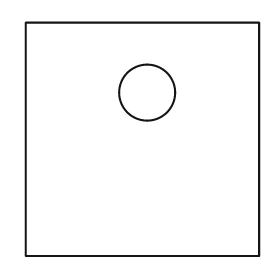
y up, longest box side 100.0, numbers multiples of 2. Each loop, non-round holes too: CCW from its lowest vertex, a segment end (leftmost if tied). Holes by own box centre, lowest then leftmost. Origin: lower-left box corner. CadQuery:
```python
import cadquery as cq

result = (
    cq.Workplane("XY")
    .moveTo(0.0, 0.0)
    .lineTo(100.0, 0.0)
    .lineTo(100.0, 100.0)
    .lineTo(0.0, 100.0)
    .close()
    .moveTo(52.0, 70.0)
    .circle(12.0)
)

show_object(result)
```